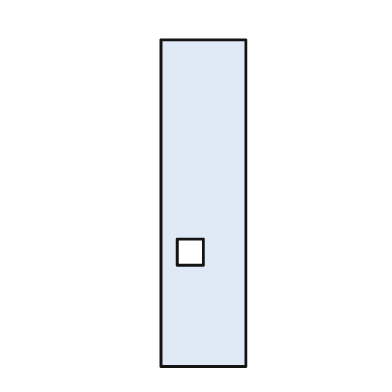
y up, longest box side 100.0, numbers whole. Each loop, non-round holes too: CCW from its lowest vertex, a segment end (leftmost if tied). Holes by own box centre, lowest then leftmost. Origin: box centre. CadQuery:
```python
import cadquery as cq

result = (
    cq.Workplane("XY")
    .moveTo(-13.0, -50.0)
    .lineTo(13.0, -50.0)
    .lineTo(13.0, 50.0)
    .lineTo(-13.0, 50.0)
    .close()
    .moveTo(-8.0, -19.0)
    .lineTo(0.0, -19.0)
    .lineTo(0.0, -11.0)
    .lineTo(-8.0, -11.0)
    .close()
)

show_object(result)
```